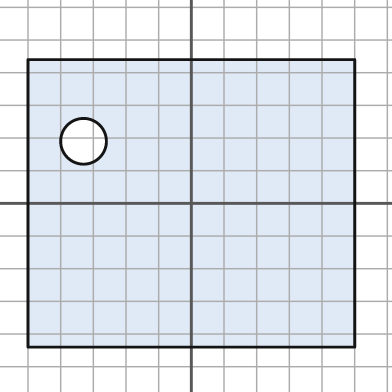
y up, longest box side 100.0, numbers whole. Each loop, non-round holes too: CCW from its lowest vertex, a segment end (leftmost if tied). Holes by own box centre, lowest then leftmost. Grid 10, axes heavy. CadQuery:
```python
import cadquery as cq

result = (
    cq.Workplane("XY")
    .moveTo(-50.0, -44.0)
    .lineTo(50.0, -44.0)
    .lineTo(50.0, 44.0)
    .lineTo(-50.0, 44.0)
    .close()
    .moveTo(-33.0, 19.0)
    .circle(7.0)
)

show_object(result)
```